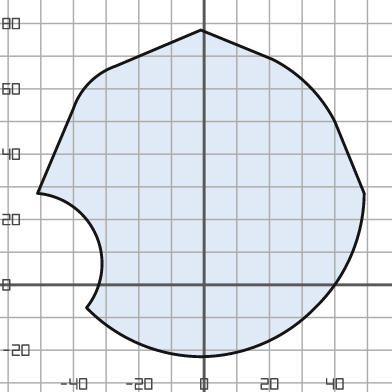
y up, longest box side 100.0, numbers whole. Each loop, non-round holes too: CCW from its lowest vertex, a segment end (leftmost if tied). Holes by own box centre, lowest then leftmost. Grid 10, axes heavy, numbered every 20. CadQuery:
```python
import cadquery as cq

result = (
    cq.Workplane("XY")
    .moveTo(-1.0, -22.0)
    .threePointArc((18.0, -18.0), (34.0, -7.0))
    .threePointArc((45.0, 9.0), (49.0, 28.0))
    .lineTo(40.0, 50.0)
    .threePointArc((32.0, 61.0), (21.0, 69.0))
    .lineTo(-1.0, 78.0)
    .lineTo(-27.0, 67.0)
    .threePointArc((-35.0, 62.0), (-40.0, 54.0))
    .lineTo(-51.0, 28.0)
    .threePointArc((-33.0, 15.0), (-36.0, -7.0))
    .threePointArc((-20.0, -18.0), (-1.0, -22.0))
    .close()
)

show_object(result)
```